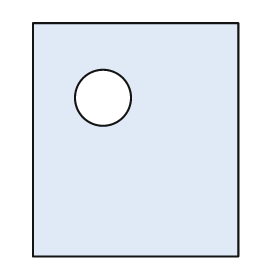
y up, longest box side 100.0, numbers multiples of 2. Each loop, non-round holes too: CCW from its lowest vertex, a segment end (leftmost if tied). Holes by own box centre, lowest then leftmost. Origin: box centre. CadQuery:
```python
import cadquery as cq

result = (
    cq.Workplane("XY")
    .moveTo(-44.0, -50.0)
    .lineTo(44.0, -50.0)
    .lineTo(44.0, 50.0)
    .lineTo(-44.0, 50.0)
    .close()
    .moveTo(-14.0, 18.0)
    .circle(12.0)
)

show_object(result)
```